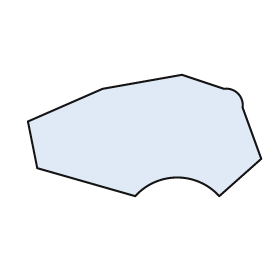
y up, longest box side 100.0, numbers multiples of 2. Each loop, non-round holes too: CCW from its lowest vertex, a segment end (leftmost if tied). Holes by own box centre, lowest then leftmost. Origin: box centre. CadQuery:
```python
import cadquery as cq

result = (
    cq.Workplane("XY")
    .moveTo(-4.0, -26.0)
    .threePointArc((14.0, -18.0), (32.0, -26.0))
    .lineTo(50.0, -10.0)
    .lineTo(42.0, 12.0)
    .threePointArc((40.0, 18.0), (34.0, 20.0))
    .lineTo(16.0, 26.0)
    .lineTo(-18.0, 20.0)
    .lineTo(-50.0, 6.0)
    .lineTo(-46.0, -14.0)
    .close()
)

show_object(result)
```